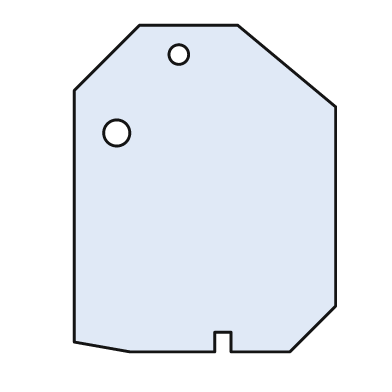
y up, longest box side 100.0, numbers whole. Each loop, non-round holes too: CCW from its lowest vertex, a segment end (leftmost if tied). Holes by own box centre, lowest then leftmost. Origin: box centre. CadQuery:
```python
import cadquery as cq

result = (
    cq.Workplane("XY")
    .moveTo(-23.0, -50.0)
    .lineTo(3.0, -50.0)
    .lineTo(3.0, -44.0)
    .lineTo(8.0, -44.0)
    .lineTo(8.0, -50.0)
    .lineTo(26.0, -50.0)
    .lineTo(40.0, -36.0)
    .lineTo(40.0, 25.0)
    .lineTo(10.0, 50.0)
    .lineTo(-20.0, 50.0)
    .lineTo(-40.0, 30.0)
    .lineTo(-40.0, -47.0)
    .close()
    .moveTo(-27.0, 17.0)
    .circle(4.0)
    .moveTo(-8.0, 41.0)
    .circle(3.0)
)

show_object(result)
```